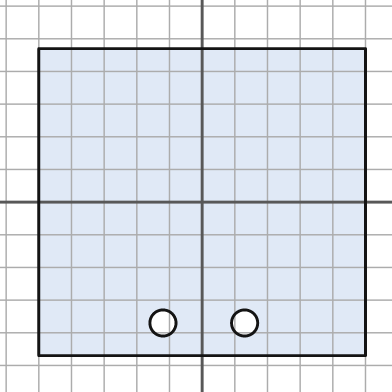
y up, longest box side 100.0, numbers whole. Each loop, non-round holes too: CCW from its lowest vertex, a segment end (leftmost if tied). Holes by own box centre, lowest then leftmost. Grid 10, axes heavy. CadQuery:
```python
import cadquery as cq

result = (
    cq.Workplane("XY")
    .moveTo(-50.0, -47.0)
    .lineTo(50.0, -47.0)
    .lineTo(50.0, 47.0)
    .lineTo(-50.0, 47.0)
    .close()
    .moveTo(-12.0, -37.0)
    .circle(4.0)
    .moveTo(13.0, -37.0)
    .circle(4.0)
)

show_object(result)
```